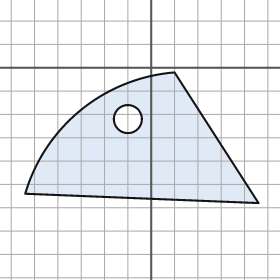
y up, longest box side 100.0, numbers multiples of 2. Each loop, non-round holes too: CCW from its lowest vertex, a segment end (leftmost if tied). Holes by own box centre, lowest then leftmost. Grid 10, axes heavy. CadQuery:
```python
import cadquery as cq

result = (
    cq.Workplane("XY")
    .moveTo(46.0, -58.0)
    .lineTo(10.0, -2.0)
    .threePointArc((-30.0, -18.0), (-54.0, -54.0))
    .close()
    .moveTo(-10.0, -22.0)
    .circle(6.0)
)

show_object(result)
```